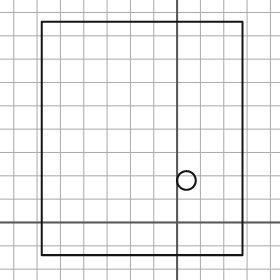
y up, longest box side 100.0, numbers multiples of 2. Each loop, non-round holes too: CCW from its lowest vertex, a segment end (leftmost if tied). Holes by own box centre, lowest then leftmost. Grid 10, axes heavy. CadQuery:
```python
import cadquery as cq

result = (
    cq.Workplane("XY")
    .moveTo(-58.0, -14.0)
    .lineTo(28.0, -14.0)
    .lineTo(28.0, 86.0)
    .lineTo(-58.0, 86.0)
    .close()
    .moveTo(4.0, 18.0)
    .circle(4.0)
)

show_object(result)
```